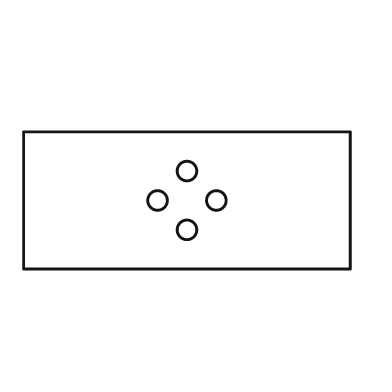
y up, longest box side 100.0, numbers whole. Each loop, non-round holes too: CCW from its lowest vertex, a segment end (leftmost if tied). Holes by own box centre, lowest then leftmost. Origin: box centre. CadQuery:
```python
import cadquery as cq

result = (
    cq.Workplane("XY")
    .moveTo(-50.0, -21.0)
    .lineTo(50.0, -21.0)
    .lineTo(50.0, 21.0)
    .lineTo(-50.0, 21.0)
    .close()
    .moveTo(0.0, -9.0)
    .circle(3.0)
    .moveTo(-9.0, 0.0)
    .circle(3.0)
    .moveTo(9.0, 0.0)
    .circle(3.0)
    .moveTo(0.0, 9.0)
    .circle(3.0)
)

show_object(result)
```